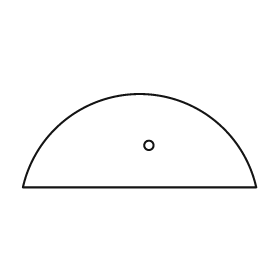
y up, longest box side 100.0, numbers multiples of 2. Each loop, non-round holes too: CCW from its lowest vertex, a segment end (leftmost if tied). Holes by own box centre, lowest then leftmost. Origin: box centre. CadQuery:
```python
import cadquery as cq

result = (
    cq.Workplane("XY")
    .moveTo(-50.0, -20.0)
    .lineTo(50.0, -20.0)
    .threePointArc((0.0, 20.0), (-50.0, -20.0))
    .close()
    .moveTo(4.0, -2.0)
    .circle(2.0)
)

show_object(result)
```